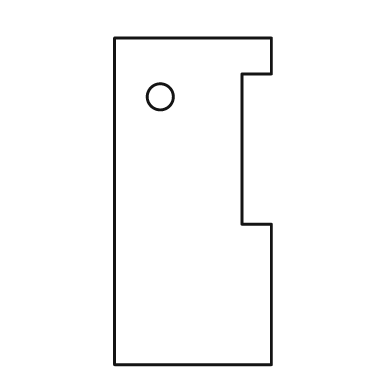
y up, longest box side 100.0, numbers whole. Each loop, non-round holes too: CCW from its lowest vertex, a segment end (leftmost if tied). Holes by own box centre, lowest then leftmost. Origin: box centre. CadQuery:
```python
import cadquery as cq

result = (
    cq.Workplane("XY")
    .moveTo(-24.0, -50.0)
    .lineTo(24.0, -50.0)
    .lineTo(24.0, -7.0)
    .lineTo(15.0, -7.0)
    .lineTo(15.0, 39.0)
    .lineTo(24.0, 39.0)
    .lineTo(24.0, 50.0)
    .lineTo(-24.0, 50.0)
    .close()
    .moveTo(-10.0, 32.0)
    .circle(4.0)
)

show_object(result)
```